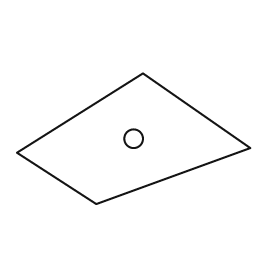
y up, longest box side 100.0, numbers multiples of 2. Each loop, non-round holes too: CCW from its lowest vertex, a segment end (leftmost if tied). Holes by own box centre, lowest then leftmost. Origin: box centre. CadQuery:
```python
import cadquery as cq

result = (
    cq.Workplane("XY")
    .moveTo(-16.0, -28.0)
    .lineTo(50.0, -4.0)
    .lineTo(4.0, 28.0)
    .lineTo(-50.0, -6.0)
    .close()
    .moveTo(0.0, 0.0)
    .circle(4.0)
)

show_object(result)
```